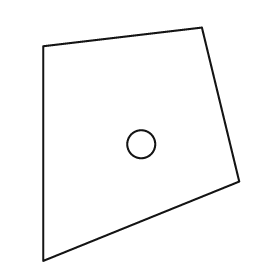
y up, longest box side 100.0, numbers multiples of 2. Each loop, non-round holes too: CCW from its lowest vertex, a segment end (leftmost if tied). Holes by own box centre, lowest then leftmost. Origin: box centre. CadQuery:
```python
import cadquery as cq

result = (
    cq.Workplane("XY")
    .moveTo(-42.0, -50.0)
    .lineTo(42.0, -16.0)
    .lineTo(26.0, 50.0)
    .lineTo(-42.0, 42.0)
    .close()
    .moveTo(0.0, 0.0)
    .circle(6.0)
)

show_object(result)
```